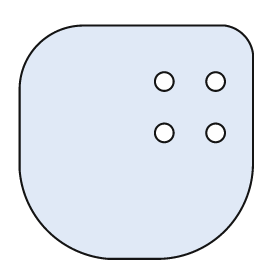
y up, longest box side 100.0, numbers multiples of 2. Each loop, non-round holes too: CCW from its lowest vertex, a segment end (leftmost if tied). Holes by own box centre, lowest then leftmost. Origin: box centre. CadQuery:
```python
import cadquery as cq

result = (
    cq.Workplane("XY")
    .moveTo(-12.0, -50.0)
    .lineTo(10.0, -50.0)
    .threePointArc((38.0, -38.0), (50.0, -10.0))
    .lineTo(50.0, 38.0)
    .threePointArc((46.0, 46.0), (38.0, 50.0))
    .lineTo(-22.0, 50.0)
    .threePointArc((-42.0, 42.0), (-50.0, 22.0))
    .lineTo(-50.0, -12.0)
    .threePointArc((-38.0, -38.0), (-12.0, -50.0))
    .close()
    .moveTo(12.0, 4.0)
    .circle(4.0)
    .moveTo(34.0, 4.0)
    .circle(4.0)
    .moveTo(12.0, 26.0)
    .circle(4.0)
    .moveTo(34.0, 26.0)
    .circle(4.0)
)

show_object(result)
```